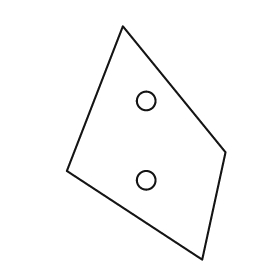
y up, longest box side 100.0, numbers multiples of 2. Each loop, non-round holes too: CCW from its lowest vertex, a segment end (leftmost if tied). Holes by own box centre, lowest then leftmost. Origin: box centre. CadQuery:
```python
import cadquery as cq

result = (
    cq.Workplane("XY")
    .moveTo(24.0, -50.0)
    .lineTo(34.0, -4.0)
    .lineTo(-10.0, 50.0)
    .lineTo(-34.0, -12.0)
    .close()
    .moveTo(0.0, -16.0)
    .circle(4.0)
    .moveTo(0.0, 18.0)
    .circle(4.0)
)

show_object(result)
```